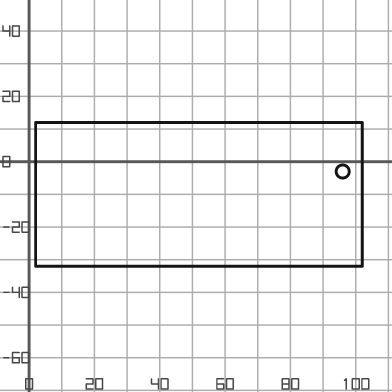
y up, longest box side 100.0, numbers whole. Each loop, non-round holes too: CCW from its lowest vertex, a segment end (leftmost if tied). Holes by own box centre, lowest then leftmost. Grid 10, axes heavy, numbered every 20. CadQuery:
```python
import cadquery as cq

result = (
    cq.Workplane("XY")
    .moveTo(2.0, -32.0)
    .lineTo(102.0, -32.0)
    .lineTo(102.0, 12.0)
    .lineTo(2.0, 12.0)
    .close()
    .moveTo(96.0, -3.0)
    .circle(2.0)
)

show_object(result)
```